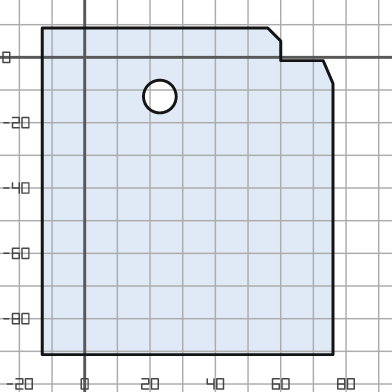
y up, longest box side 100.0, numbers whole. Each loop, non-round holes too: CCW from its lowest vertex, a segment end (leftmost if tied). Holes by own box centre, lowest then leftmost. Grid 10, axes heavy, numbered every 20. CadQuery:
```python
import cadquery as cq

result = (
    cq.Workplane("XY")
    .moveTo(-13.0, -91.0)
    .lineTo(76.0, -91.0)
    .lineTo(76.0, -8.0)
    .lineTo(73.0, -1.0)
    .lineTo(60.0, -1.0)
    .lineTo(60.0, 5.0)
    .lineTo(56.0, 9.0)
    .lineTo(-13.0, 9.0)
    .close()
    .moveTo(23.0, -12.0)
    .circle(5.0)
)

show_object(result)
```